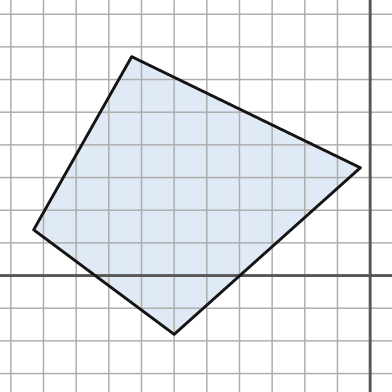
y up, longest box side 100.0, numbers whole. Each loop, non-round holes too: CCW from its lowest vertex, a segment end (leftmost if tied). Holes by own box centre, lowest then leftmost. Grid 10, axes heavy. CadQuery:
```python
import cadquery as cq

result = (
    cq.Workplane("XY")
    .moveTo(-60.0, -18.0)
    .lineTo(-3.0, 33.0)
    .lineTo(-73.0, 67.0)
    .lineTo(-103.0, 14.0)
    .close()
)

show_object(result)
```